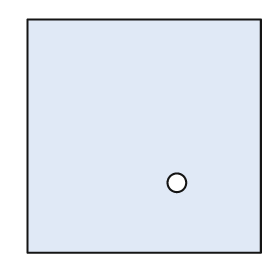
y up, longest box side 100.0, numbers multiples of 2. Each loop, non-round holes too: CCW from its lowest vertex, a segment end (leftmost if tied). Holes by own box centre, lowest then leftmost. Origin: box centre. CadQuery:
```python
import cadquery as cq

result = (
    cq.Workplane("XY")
    .moveTo(-50.0, -50.0)
    .lineTo(50.0, -50.0)
    .lineTo(50.0, 50.0)
    .lineTo(-50.0, 50.0)
    .close()
    .moveTo(14.0, -20.0)
    .circle(4.0)
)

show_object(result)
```